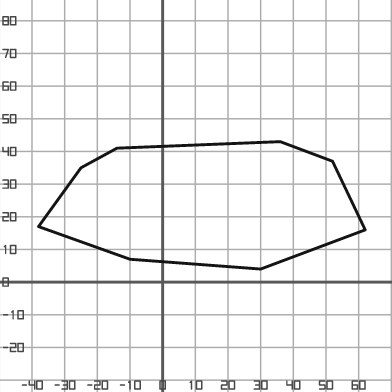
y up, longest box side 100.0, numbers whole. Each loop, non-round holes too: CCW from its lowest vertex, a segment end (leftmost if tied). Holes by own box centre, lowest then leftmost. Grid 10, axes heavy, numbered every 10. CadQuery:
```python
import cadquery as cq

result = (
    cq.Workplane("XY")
    .moveTo(30.0, 4.0)
    .lineTo(62.0, 16.0)
    .lineTo(52.0, 37.0)
    .lineTo(36.0, 43.0)
    .lineTo(-14.0, 41.0)
    .lineTo(-25.0, 35.0)
    .lineTo(-38.0, 17.0)
    .lineTo(-10.0, 7.0)
    .close()
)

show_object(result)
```